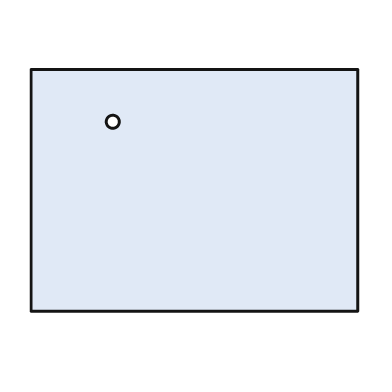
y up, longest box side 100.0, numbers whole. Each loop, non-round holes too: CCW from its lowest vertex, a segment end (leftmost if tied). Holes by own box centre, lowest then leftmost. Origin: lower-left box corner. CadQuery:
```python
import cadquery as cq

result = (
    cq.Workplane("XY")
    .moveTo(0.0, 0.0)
    .lineTo(100.0, 0.0)
    .lineTo(100.0, 74.0)
    .lineTo(0.0, 74.0)
    .close()
    .moveTo(25.0, 58.0)
    .circle(2.0)
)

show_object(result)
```